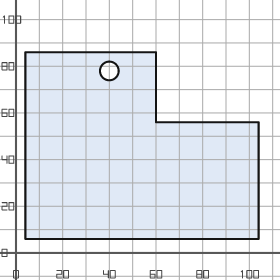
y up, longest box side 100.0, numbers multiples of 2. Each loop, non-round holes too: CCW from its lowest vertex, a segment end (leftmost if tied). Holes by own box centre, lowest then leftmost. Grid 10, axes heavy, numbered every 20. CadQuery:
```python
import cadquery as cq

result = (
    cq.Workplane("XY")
    .moveTo(4.0, 6.0)
    .lineTo(104.0, 6.0)
    .lineTo(104.0, 56.0)
    .lineTo(60.0, 56.0)
    .lineTo(60.0, 86.0)
    .lineTo(4.0, 86.0)
    .close()
    .moveTo(40.0, 78.0)
    .circle(4.0)
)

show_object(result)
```